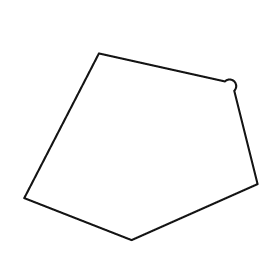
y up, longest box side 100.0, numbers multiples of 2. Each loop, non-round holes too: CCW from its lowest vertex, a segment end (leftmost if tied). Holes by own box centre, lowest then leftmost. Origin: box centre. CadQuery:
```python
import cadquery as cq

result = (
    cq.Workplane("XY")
    .moveTo(-4.0, -40.0)
    .lineTo(50.0, -16.0)
    .lineTo(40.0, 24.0)
    .threePointArc((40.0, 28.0), (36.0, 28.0))
    .lineTo(-18.0, 40.0)
    .lineTo(-50.0, -22.0)
    .close()
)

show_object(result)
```